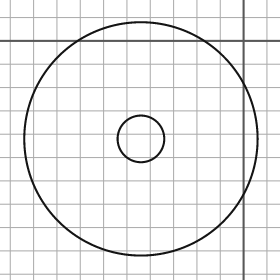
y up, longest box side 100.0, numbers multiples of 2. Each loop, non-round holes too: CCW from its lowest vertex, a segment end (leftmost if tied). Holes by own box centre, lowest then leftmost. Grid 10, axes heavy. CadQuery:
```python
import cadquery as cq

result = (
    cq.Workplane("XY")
    .moveTo(-44.0, -42.0)
    .circle(50.0)
    .moveTo(-44.0, -42.0)
    .circle(10.0)
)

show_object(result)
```